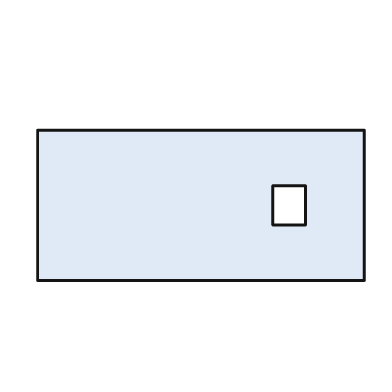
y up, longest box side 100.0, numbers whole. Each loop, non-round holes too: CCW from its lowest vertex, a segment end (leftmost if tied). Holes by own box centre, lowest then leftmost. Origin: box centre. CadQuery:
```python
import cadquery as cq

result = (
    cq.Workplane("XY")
    .moveTo(-50.0, -23.0)
    .lineTo(50.0, -23.0)
    .lineTo(50.0, 23.0)
    .lineTo(-50.0, 23.0)
    .close()
    .moveTo(22.0, -6.0)
    .lineTo(32.0, -6.0)
    .lineTo(32.0, 6.0)
    .lineTo(22.0, 6.0)
    .close()
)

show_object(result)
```